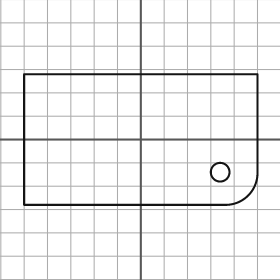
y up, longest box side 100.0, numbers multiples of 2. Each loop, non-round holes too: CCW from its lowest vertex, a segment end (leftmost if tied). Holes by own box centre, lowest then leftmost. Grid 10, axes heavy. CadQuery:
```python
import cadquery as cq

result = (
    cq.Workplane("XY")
    .moveTo(-50.0, -28.0)
    .lineTo(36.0, -28.0)
    .threePointArc((46.0, -24.0), (50.0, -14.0))
    .lineTo(50.0, 28.0)
    .lineTo(-50.0, 28.0)
    .close()
    .moveTo(34.0, -14.0)
    .circle(4.0)
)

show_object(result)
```